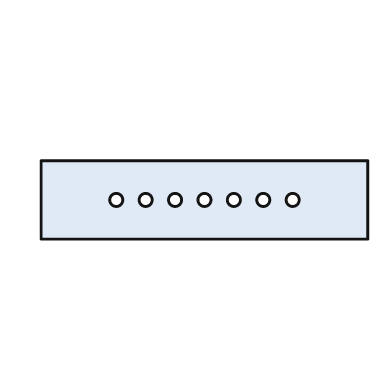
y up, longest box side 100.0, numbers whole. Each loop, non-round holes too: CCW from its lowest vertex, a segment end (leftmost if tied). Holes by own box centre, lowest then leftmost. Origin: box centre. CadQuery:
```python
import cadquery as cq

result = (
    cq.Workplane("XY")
    .moveTo(-50.0, -12.0)
    .lineTo(50.0, -12.0)
    .lineTo(50.0, 12.0)
    .lineTo(-50.0, 12.0)
    .close()
    .moveTo(-27.0, 0.0)
    .circle(2.0)
    .moveTo(-18.0, 0.0)
    .circle(2.0)
    .moveTo(-9.0, 0.0)
    .circle(2.0)
    .moveTo(0.0, 0.0)
    .circle(2.0)
    .moveTo(9.0, 0.0)
    .circle(2.0)
    .moveTo(18.0, 0.0)
    .circle(2.0)
    .moveTo(27.0, 0.0)
    .circle(2.0)
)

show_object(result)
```